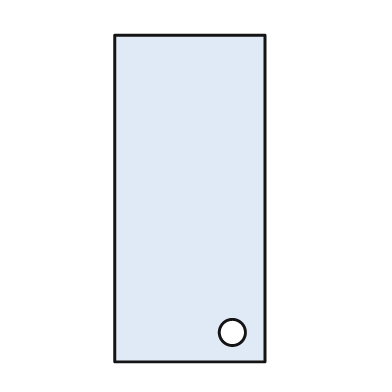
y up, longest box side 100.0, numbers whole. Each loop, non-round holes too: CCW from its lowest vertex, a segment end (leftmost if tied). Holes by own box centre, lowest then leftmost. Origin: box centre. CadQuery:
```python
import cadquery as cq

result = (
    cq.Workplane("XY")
    .moveTo(-23.0, -50.0)
    .lineTo(23.0, -50.0)
    .lineTo(23.0, 50.0)
    .lineTo(-23.0, 50.0)
    .close()
    .moveTo(13.0, -41.0)
    .circle(4.0)
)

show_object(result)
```